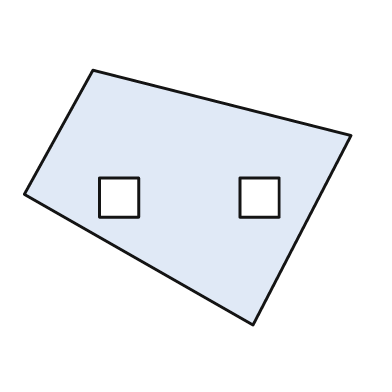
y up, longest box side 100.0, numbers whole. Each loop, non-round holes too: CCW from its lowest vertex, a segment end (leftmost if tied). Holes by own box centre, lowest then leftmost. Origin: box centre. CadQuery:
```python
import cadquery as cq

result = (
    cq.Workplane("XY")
    .moveTo(20.0, -39.0)
    .lineTo(50.0, 19.0)
    .lineTo(-29.0, 39.0)
    .lineTo(-50.0, 1.0)
    .close()
    .moveTo(-27.0, -6.0)
    .lineTo(-15.0, -6.0)
    .lineTo(-15.0, 6.0)
    .lineTo(-27.0, 6.0)
    .close()
    .moveTo(16.0, -6.0)
    .lineTo(28.0, -6.0)
    .lineTo(28.0, 6.0)
    .lineTo(16.0, 6.0)
    .close()
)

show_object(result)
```